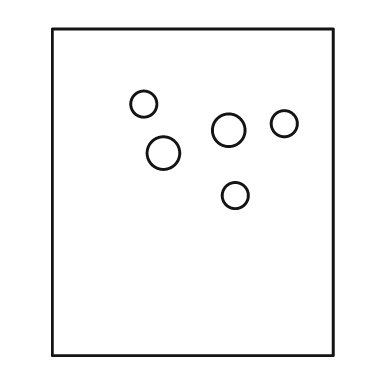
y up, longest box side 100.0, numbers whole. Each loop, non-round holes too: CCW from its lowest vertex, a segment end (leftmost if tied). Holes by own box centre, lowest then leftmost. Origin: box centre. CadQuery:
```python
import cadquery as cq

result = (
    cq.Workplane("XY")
    .moveTo(-43.0, -50.0)
    .lineTo(43.0, -50.0)
    .lineTo(43.0, 50.0)
    .lineTo(-43.0, 50.0)
    .close()
    .moveTo(13.0, -1.0)
    .circle(4.0)
    .moveTo(-9.0, 12.0)
    .circle(5.0)
    .moveTo(11.0, 19.0)
    .circle(5.0)
    .moveTo(28.0, 21.0)
    .circle(4.0)
    .moveTo(-15.0, 27.0)
    .circle(4.0)
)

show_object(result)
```